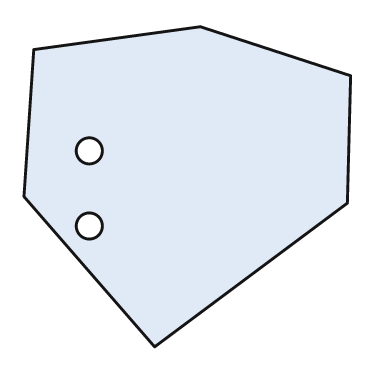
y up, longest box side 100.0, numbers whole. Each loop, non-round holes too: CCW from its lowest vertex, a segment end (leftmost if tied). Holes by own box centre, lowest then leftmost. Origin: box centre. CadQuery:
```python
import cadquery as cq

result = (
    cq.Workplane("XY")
    .moveTo(-10.0, -49.0)
    .lineTo(49.0, -5.0)
    .lineTo(50.0, 34.0)
    .lineTo(4.0, 49.0)
    .lineTo(-47.0, 42.0)
    .lineTo(-50.0, -3.0)
    .close()
    .moveTo(-30.0, -12.0)
    .circle(4.0)
    .moveTo(-30.0, 11.0)
    .circle(4.0)
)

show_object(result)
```